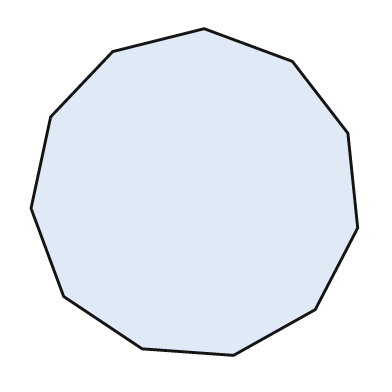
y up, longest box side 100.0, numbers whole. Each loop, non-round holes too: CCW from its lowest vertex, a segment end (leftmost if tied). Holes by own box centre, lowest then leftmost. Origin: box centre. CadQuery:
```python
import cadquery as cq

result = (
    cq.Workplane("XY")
    .moveTo(12.0, -50.0)
    .lineTo(37.0, -36.0)
    .lineTo(50.0, -11.0)
    .lineTo(47.0, 18.0)
    .lineTo(30.0, 40.0)
    .lineTo(3.0, 50.0)
    .lineTo(-25.0, 43.0)
    .lineTo(-44.0, 23.0)
    .lineTo(-50.0, -5.0)
    .lineTo(-40.0, -32.0)
    .lineTo(-16.0, -48.0)
    .close()
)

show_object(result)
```